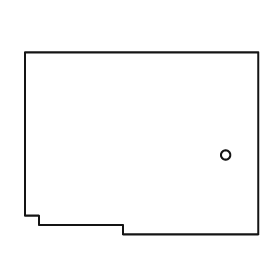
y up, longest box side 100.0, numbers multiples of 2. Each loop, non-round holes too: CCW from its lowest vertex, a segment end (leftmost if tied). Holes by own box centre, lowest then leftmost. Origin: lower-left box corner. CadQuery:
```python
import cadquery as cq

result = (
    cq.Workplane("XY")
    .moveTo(42.0, 0.0)
    .lineTo(100.0, 0.0)
    .lineTo(100.0, 78.0)
    .lineTo(0.0, 78.0)
    .lineTo(0.0, 8.0)
    .lineTo(6.0, 8.0)
    .lineTo(6.0, 4.0)
    .lineTo(42.0, 4.0)
    .close()
    .moveTo(86.0, 34.0)
    .circle(2.0)
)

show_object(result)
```